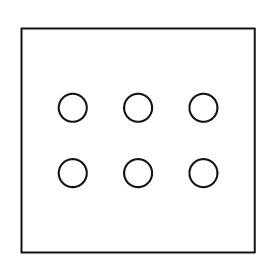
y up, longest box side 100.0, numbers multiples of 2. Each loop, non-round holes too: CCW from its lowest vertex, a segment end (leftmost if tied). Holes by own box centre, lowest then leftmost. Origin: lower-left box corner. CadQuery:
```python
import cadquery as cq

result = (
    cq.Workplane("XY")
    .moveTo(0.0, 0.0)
    .lineTo(100.0, 0.0)
    .lineTo(100.0, 96.0)
    .lineTo(0.0, 96.0)
    .close()
    .moveTo(22.0, 34.0)
    .circle(6.0)
    .moveTo(50.0, 34.0)
    .circle(6.0)
    .moveTo(78.0, 34.0)
    .circle(6.0)
    .moveTo(22.0, 62.0)
    .circle(6.0)
    .moveTo(50.0, 62.0)
    .circle(6.0)
    .moveTo(78.0, 62.0)
    .circle(6.0)
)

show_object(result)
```